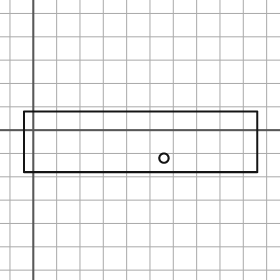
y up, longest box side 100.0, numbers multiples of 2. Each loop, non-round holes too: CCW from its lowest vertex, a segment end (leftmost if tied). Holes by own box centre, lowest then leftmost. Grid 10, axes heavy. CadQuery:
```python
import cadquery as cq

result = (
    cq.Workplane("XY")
    .moveTo(-4.0, -18.0)
    .lineTo(96.0, -18.0)
    .lineTo(96.0, 8.0)
    .lineTo(-4.0, 8.0)
    .close()
    .moveTo(56.0, -12.0)
    .circle(2.0)
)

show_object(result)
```